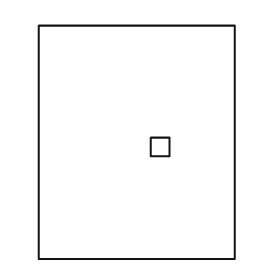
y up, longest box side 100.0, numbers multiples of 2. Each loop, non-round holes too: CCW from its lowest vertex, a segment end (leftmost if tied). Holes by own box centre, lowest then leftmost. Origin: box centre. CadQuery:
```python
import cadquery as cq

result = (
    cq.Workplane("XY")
    .moveTo(-42.0, -50.0)
    .lineTo(42.0, -50.0)
    .lineTo(42.0, 50.0)
    .lineTo(-42.0, 50.0)
    .close()
    .moveTo(6.0, -6.0)
    .lineTo(14.0, -6.0)
    .lineTo(14.0, 2.0)
    .lineTo(6.0, 2.0)
    .close()
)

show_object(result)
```